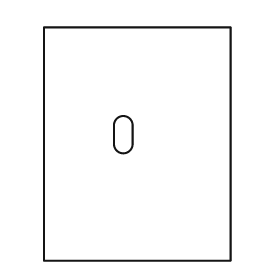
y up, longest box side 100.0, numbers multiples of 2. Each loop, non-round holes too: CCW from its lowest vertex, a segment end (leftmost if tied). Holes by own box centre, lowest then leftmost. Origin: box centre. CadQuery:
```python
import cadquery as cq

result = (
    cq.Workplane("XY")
    .moveTo(-40.0, -50.0)
    .lineTo(40.0, -50.0)
    .lineTo(40.0, 50.0)
    .lineTo(-40.0, 50.0)
    .close()
    .moveTo(-10.0, 0.0)
    .threePointArc((-6.0, -4.0), (-2.0, 0.0))
    .lineTo(-2.0, 8.0)
    .threePointArc((-6.0, 12.0), (-10.0, 8.0))
    .close()
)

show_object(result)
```